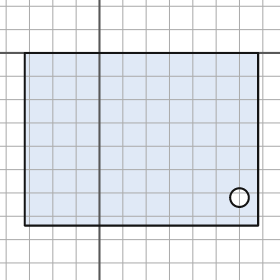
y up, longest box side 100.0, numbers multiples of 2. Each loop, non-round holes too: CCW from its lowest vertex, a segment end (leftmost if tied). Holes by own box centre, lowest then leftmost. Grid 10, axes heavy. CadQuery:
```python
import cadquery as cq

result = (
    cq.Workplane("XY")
    .moveTo(-32.0, -74.0)
    .lineTo(68.0, -74.0)
    .lineTo(68.0, 0.0)
    .lineTo(-32.0, 0.0)
    .close()
    .moveTo(60.0, -62.0)
    .circle(4.0)
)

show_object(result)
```